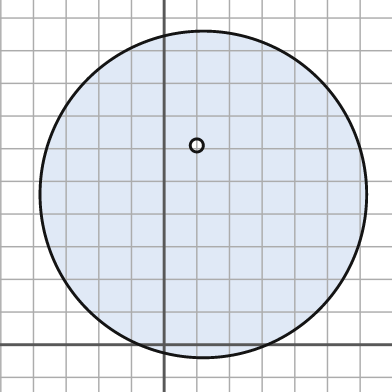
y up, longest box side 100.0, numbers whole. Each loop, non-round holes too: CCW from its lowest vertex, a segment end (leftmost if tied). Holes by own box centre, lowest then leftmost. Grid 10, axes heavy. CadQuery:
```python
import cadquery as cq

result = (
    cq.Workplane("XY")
    .moveTo(12.0, 46.0)
    .circle(50.0)
    .moveTo(10.0, 61.0)
    .circle(2.0)
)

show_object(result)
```